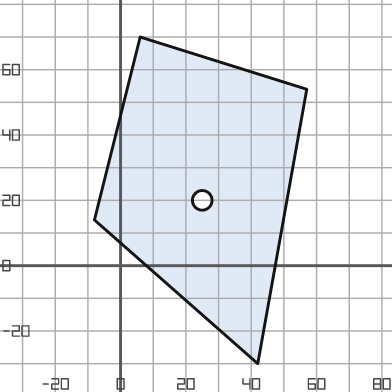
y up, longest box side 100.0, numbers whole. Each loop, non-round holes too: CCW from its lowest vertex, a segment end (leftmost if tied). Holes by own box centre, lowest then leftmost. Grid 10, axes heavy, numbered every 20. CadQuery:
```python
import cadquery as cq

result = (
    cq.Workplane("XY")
    .moveTo(42.0, -30.0)
    .lineTo(57.0, 54.0)
    .lineTo(6.0, 70.0)
    .lineTo(-8.0, 14.0)
    .close()
    .moveTo(25.0, 20.0)
    .circle(3.0)
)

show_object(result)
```